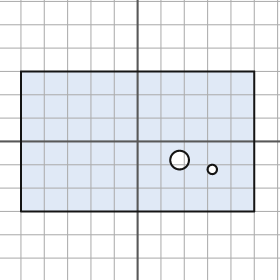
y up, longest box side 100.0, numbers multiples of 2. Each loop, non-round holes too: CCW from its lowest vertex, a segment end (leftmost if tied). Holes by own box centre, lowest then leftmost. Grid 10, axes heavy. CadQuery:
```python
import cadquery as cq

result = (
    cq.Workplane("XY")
    .moveTo(-50.0, -30.0)
    .lineTo(50.0, -30.0)
    .lineTo(50.0, 30.0)
    .lineTo(-50.0, 30.0)
    .close()
    .moveTo(32.0, -12.0)
    .circle(2.0)
    .moveTo(18.0, -8.0)
    .circle(4.0)
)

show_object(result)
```